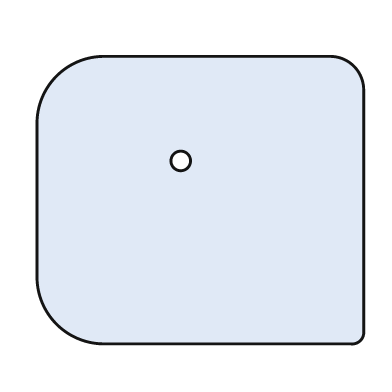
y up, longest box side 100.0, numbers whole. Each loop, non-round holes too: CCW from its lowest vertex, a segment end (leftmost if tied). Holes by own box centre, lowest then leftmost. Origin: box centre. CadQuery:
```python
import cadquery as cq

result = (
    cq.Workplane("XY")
    .moveTo(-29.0, -44.0)
    .lineTo(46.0, -44.0)
    .threePointArc((49.0, -43.0), (50.0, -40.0))
    .lineTo(50.0, 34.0)
    .threePointArc((47.0, 41.0), (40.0, 44.0))
    .lineTo(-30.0, 44.0)
    .threePointArc((-44.0, 38.0), (-50.0, 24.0))
    .lineTo(-50.0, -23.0)
    .threePointArc((-44.0, -38.0), (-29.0, -44.0))
    .close()
    .moveTo(-6.0, 12.0)
    .circle(3.0)
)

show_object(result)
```